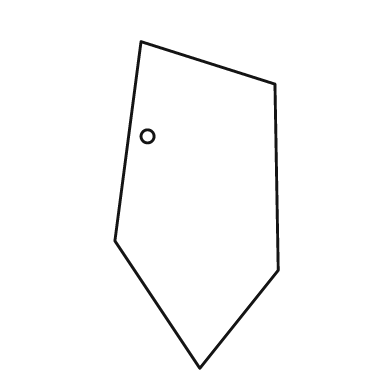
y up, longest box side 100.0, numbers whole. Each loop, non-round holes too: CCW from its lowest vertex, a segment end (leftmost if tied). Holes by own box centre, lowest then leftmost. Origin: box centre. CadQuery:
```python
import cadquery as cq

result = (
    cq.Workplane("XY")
    .moveTo(1.0, -50.0)
    .lineTo(25.0, -20.0)
    .lineTo(24.0, 37.0)
    .lineTo(-17.0, 50.0)
    .lineTo(-25.0, -11.0)
    .close()
    .moveTo(-15.0, 21.0)
    .circle(2.0)
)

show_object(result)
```